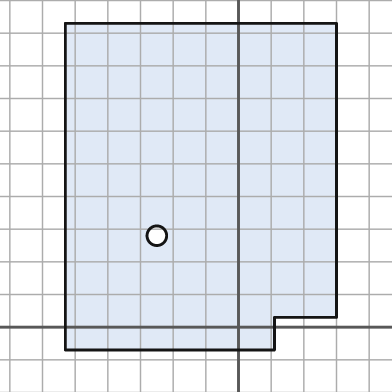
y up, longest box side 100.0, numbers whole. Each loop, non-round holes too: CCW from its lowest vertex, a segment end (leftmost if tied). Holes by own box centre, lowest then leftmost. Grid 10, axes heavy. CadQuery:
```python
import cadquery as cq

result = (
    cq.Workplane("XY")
    .moveTo(-53.0, -7.0)
    .lineTo(11.0, -7.0)
    .lineTo(11.0, 3.0)
    .lineTo(30.0, 3.0)
    .lineTo(30.0, 93.0)
    .lineTo(-53.0, 93.0)
    .close()
    .moveTo(-25.0, 28.0)
    .circle(3.0)
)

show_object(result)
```